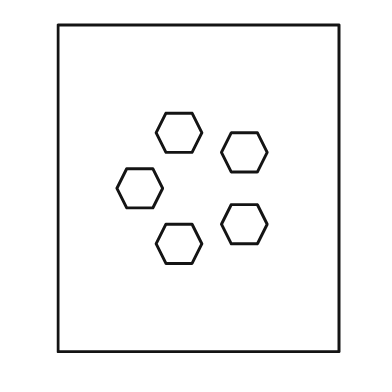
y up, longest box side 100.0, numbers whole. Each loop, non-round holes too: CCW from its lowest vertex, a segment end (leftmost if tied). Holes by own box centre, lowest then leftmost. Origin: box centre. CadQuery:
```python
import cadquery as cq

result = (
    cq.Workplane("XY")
    .moveTo(-43.0, -50.0)
    .lineTo(43.0, -50.0)
    .lineTo(43.0, 50.0)
    .lineTo(-43.0, 50.0)
    .close()
    .moveTo(-10.0, -23.0)
    .lineTo(-2.0, -23.0)
    .lineTo(1.0, -17.0)
    .lineTo(-2.0, -11.0)
    .lineTo(-10.0, -11.0)
    .lineTo(-13.0, -17.0)
    .close()
    .moveTo(10.0, -17.0)
    .lineTo(18.0, -17.0)
    .lineTo(21.0, -11.0)
    .lineTo(18.0, -5.0)
    .lineTo(10.0, -5.0)
    .lineTo(7.0, -11.0)
    .close()
    .moveTo(-22.0, -6.0)
    .lineTo(-14.0, -6.0)
    .lineTo(-11.0, 0.0)
    .lineTo(-14.0, 6.0)
    .lineTo(-22.0, 6.0)
    .lineTo(-25.0, 0.0)
    .close()
    .moveTo(10.0, 5.0)
    .lineTo(18.0, 5.0)
    .lineTo(21.0, 11.0)
    .lineTo(18.0, 17.0)
    .lineTo(10.0, 17.0)
    .lineTo(7.0, 11.0)
    .close()
    .moveTo(-10.0, 11.0)
    .lineTo(-2.0, 11.0)
    .lineTo(1.0, 17.0)
    .lineTo(-2.0, 23.0)
    .lineTo(-10.0, 23.0)
    .lineTo(-13.0, 17.0)
    .close()
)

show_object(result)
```